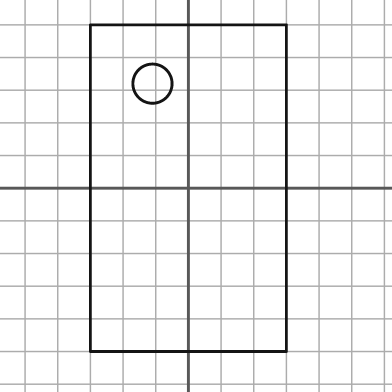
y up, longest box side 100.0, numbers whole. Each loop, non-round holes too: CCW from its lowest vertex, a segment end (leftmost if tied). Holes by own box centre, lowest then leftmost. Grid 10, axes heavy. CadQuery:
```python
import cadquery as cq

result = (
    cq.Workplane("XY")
    .moveTo(-30.0, -50.0)
    .lineTo(30.0, -50.0)
    .lineTo(30.0, 50.0)
    .lineTo(-30.0, 50.0)
    .close()
    .moveTo(-11.0, 32.0)
    .circle(6.0)
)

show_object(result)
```